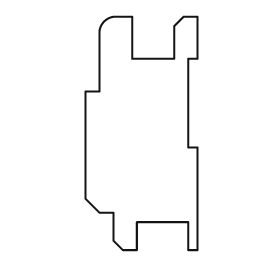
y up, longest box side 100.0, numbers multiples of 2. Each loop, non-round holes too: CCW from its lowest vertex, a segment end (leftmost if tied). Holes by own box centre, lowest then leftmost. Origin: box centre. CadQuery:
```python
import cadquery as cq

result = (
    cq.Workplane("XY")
    .moveTo(-8.0, -50.0)
    .lineTo(-2.0, -50.0)
    .lineTo(-2.0, -38.0)
    .lineTo(20.0, -38.0)
    .lineTo(20.0, -50.0)
    .lineTo(24.0, -50.0)
    .lineTo(24.0, -6.0)
    .lineTo(20.0, -6.0)
    .lineTo(20.0, 32.0)
    .lineTo(24.0, 32.0)
    .lineTo(24.0, 50.0)
    .lineTo(18.0, 50.0)
    .lineTo(14.0, 46.0)
    .lineTo(14.0, 32.0)
    .lineTo(-4.0, 32.0)
    .lineTo(-4.0, 50.0)
    .lineTo(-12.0, 50.0)
    .threePointArc((-16.0, 48.0), (-18.0, 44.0))
    .lineTo(-18.0, 18.0)
    .lineTo(-24.0, 18.0)
    .lineTo(-24.0, -28.0)
    .lineTo(-18.0, -34.0)
    .lineTo(-12.0, -34.0)
    .lineTo(-12.0, -46.0)
    .close()
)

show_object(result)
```